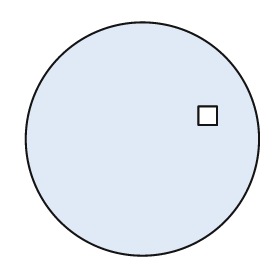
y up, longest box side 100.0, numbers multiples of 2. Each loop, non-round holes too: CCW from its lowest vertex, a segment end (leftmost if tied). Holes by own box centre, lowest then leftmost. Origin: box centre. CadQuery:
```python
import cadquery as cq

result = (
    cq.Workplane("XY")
    .moveTo(0.0, 0.0)
    .circle(50.0)
    .moveTo(24.0, 6.0)
    .lineTo(32.0, 6.0)
    .lineTo(32.0, 14.0)
    .lineTo(24.0, 14.0)
    .close()
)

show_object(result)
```